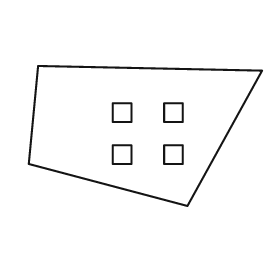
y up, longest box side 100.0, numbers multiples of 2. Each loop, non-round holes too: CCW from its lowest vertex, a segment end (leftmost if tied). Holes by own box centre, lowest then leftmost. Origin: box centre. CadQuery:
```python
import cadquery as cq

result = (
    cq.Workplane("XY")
    .moveTo(18.0, -30.0)
    .lineTo(50.0, 28.0)
    .lineTo(-46.0, 30.0)
    .lineTo(-50.0, -12.0)
    .close()
    .moveTo(-14.0, -12.0)
    .lineTo(-6.0, -12.0)
    .lineTo(-6.0, -4.0)
    .lineTo(-14.0, -4.0)
    .close()
    .moveTo(8.0, -12.0)
    .lineTo(16.0, -12.0)
    .lineTo(16.0, -4.0)
    .lineTo(8.0, -4.0)
    .close()
    .moveTo(-14.0, 6.0)
    .lineTo(-6.0, 6.0)
    .lineTo(-6.0, 14.0)
    .lineTo(-14.0, 14.0)
    .close()
    .moveTo(8.0, 6.0)
    .lineTo(16.0, 6.0)
    .lineTo(16.0, 14.0)
    .lineTo(8.0, 14.0)
    .close()
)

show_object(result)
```